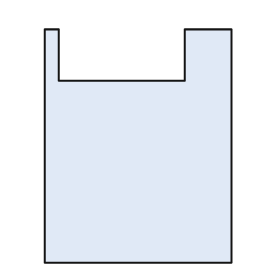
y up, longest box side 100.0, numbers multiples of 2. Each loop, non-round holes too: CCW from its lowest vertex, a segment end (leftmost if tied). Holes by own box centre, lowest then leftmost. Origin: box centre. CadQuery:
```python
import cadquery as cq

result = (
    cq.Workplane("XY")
    .moveTo(-40.0, -50.0)
    .lineTo(40.0, -50.0)
    .lineTo(40.0, 50.0)
    .lineTo(20.0, 50.0)
    .lineTo(20.0, 28.0)
    .lineTo(-34.0, 28.0)
    .lineTo(-34.0, 50.0)
    .lineTo(-40.0, 50.0)
    .close()
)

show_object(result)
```